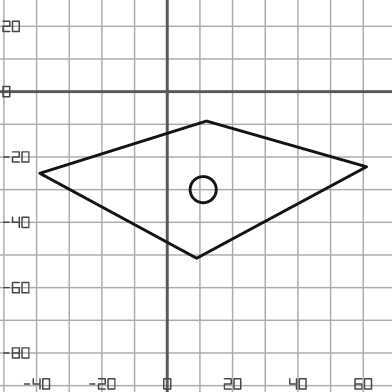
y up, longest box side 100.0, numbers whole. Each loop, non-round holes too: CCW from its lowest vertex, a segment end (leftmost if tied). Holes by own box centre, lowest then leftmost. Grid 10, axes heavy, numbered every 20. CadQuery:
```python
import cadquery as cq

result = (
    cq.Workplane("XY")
    .moveTo(9.0, -51.0)
    .lineTo(61.0, -23.0)
    .lineTo(12.0, -9.0)
    .lineTo(-39.0, -25.0)
    .close()
    .moveTo(11.0, -30.0)
    .circle(4.0)
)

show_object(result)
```